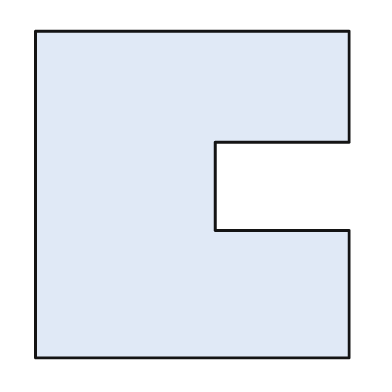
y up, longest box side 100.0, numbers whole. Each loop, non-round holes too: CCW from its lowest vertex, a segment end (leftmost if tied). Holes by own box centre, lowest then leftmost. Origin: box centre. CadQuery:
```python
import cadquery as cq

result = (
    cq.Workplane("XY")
    .moveTo(-48.0, -50.0)
    .lineTo(48.0, -50.0)
    .lineTo(48.0, -11.0)
    .lineTo(7.0, -11.0)
    .lineTo(7.0, 16.0)
    .lineTo(48.0, 16.0)
    .lineTo(48.0, 50.0)
    .lineTo(-48.0, 50.0)
    .close()
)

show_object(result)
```